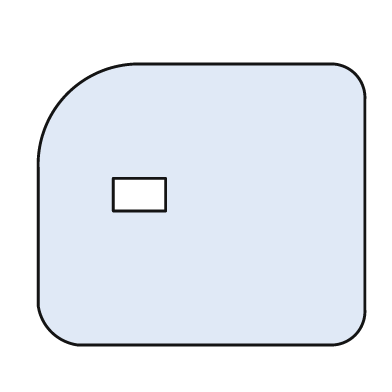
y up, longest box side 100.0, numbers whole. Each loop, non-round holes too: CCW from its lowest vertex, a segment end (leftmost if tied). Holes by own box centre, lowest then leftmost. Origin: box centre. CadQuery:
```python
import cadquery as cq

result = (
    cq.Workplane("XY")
    .moveTo(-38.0, -43.0)
    .lineTo(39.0, -43.0)
    .threePointArc((47.0, -40.0), (50.0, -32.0))
    .lineTo(50.0, 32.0)
    .threePointArc((47.0, 40.0), (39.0, 43.0))
    .lineTo(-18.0, 43.0)
    .threePointArc((-41.0, 34.0), (-50.0, 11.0))
    .lineTo(-50.0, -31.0)
    .threePointArc((-46.0, -39.0), (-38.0, -43.0))
    .close()
    .moveTo(-27.0, -2.0)
    .lineTo(-11.0, -2.0)
    .lineTo(-11.0, 8.0)
    .lineTo(-27.0, 8.0)
    .close()
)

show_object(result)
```